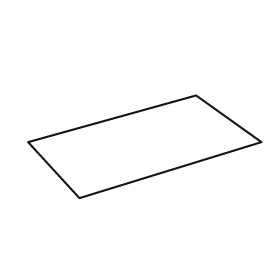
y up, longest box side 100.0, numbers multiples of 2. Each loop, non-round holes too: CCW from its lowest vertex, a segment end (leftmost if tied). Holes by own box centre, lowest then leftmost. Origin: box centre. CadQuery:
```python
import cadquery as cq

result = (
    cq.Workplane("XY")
    .moveTo(-28.0, -22.0)
    .lineTo(50.0, 2.0)
    .lineTo(22.0, 22.0)
    .lineTo(-50.0, 2.0)
    .close()
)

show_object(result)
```